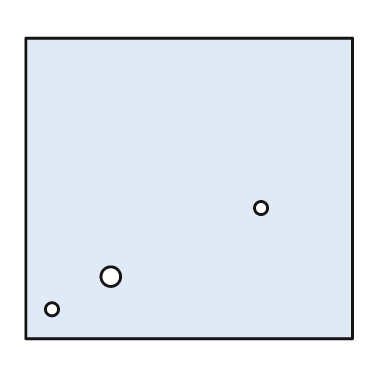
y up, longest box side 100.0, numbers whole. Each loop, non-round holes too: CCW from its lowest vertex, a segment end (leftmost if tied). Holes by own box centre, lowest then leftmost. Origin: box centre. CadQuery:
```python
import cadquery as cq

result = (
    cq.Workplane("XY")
    .moveTo(-50.0, -46.0)
    .lineTo(50.0, -46.0)
    .lineTo(50.0, 46.0)
    .lineTo(-50.0, 46.0)
    .close()
    .moveTo(-42.0, -37.0)
    .circle(2.0)
    .moveTo(-24.0, -27.0)
    .circle(3.0)
    .moveTo(22.0, -6.0)
    .circle(2.0)
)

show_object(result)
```